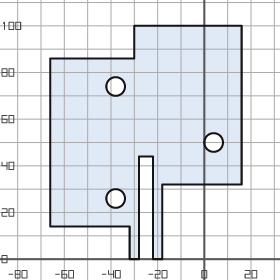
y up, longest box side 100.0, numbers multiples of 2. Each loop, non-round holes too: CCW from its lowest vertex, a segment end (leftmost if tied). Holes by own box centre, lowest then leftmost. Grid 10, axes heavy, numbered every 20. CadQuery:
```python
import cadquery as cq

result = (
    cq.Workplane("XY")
    .moveTo(-32.0, 0.0)
    .lineTo(-28.0, 0.0)
    .lineTo(-28.0, 44.0)
    .lineTo(-22.0, 44.0)
    .lineTo(-22.0, 0.0)
    .lineTo(-18.0, 0.0)
    .lineTo(-18.0, 32.0)
    .lineTo(16.0, 32.0)
    .lineTo(16.0, 100.0)
    .lineTo(-30.0, 100.0)
    .lineTo(-30.0, 86.0)
    .lineTo(-66.0, 86.0)
    .lineTo(-66.0, 14.0)
    .lineTo(-32.0, 14.0)
    .close()
    .moveTo(-38.0, 26.0)
    .circle(4.0)
    .moveTo(4.0, 50.0)
    .circle(4.0)
    .moveTo(-38.0, 74.0)
    .circle(4.0)
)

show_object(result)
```